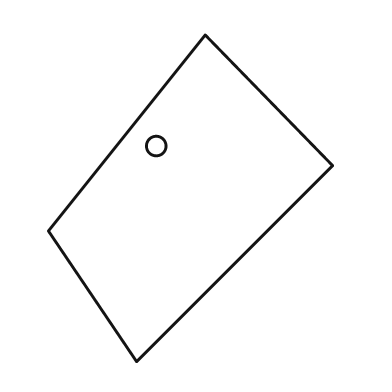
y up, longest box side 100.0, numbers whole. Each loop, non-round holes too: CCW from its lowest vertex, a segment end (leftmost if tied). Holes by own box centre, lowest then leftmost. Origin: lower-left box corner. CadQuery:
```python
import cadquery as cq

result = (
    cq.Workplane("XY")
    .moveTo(27.0, 0.0)
    .lineTo(87.0, 60.0)
    .lineTo(48.0, 100.0)
    .lineTo(0.0, 40.0)
    .close()
    .moveTo(33.0, 66.0)
    .circle(3.0)
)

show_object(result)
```